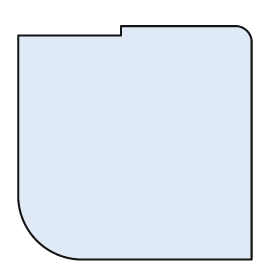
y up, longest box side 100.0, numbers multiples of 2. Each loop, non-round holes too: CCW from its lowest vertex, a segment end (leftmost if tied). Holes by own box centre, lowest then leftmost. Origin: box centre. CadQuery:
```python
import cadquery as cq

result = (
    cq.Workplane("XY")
    .moveTo(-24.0, -50.0)
    .lineTo(50.0, -50.0)
    .lineTo(50.0, 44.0)
    .threePointArc((48.0, 48.0), (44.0, 50.0))
    .lineTo(-6.0, 50.0)
    .lineTo(-6.0, 46.0)
    .lineTo(-50.0, 46.0)
    .lineTo(-50.0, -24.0)
    .threePointArc((-42.0, -42.0), (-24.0, -50.0))
    .close()
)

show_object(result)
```